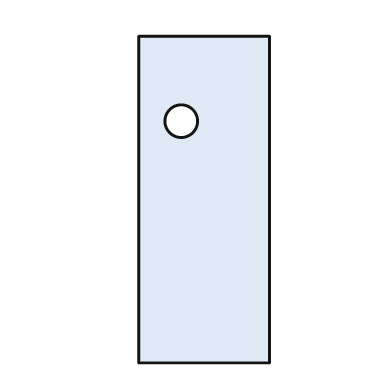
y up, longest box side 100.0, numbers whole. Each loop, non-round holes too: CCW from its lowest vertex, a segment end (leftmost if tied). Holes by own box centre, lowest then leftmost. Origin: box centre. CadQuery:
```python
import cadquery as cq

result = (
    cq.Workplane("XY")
    .moveTo(-20.0, -50.0)
    .lineTo(20.0, -50.0)
    .lineTo(20.0, 50.0)
    .lineTo(-20.0, 50.0)
    .close()
    .moveTo(-7.0, 24.0)
    .circle(5.0)
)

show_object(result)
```